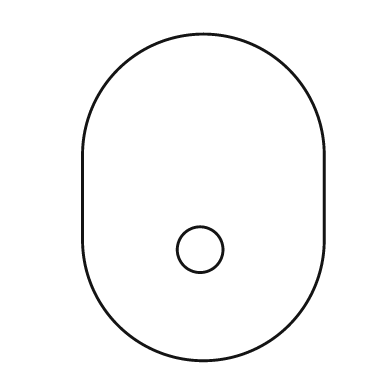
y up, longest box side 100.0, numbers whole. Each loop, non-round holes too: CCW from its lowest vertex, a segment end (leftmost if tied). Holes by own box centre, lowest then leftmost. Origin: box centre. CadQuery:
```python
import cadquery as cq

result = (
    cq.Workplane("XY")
    .moveTo(-37.0, -13.0)
    .threePointArc((0.0, -50.0), (37.0, -13.0))
    .lineTo(37.0, 13.0)
    .threePointArc((0.0, 50.0), (-37.0, 13.0))
    .close()
    .moveTo(-1.0, -16.0)
    .circle(7.0)
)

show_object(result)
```